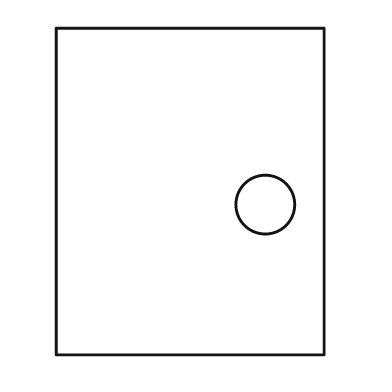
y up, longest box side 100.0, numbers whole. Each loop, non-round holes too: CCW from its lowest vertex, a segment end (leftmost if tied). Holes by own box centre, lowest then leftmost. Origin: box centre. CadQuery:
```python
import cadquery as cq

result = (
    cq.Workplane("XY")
    .moveTo(-41.0, -50.0)
    .lineTo(41.0, -50.0)
    .lineTo(41.0, 50.0)
    .lineTo(-41.0, 50.0)
    .close()
    .moveTo(23.0, -4.0)
    .circle(9.0)
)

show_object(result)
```